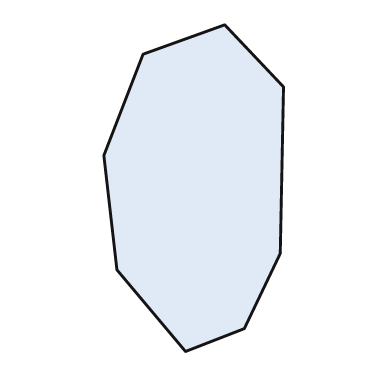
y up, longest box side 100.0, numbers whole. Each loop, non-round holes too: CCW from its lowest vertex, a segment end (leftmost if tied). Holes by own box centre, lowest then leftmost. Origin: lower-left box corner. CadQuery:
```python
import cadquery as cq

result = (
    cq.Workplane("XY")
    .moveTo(25.0, 0.0)
    .lineTo(43.0, 7.0)
    .lineTo(54.0, 30.0)
    .lineTo(55.0, 81.0)
    .lineTo(37.0, 100.0)
    .lineTo(12.0, 91.0)
    .lineTo(0.0, 60.0)
    .lineTo(4.0, 25.0)
    .close()
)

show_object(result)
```